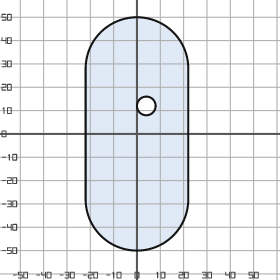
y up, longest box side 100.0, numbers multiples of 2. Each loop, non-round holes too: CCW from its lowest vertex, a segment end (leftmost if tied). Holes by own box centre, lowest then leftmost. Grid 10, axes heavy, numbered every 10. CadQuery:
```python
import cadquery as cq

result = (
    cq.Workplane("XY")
    .moveTo(-22.0, -28.0)
    .threePointArc((0.0, -50.0), (22.0, -28.0))
    .lineTo(22.0, 28.0)
    .threePointArc((0.0, 50.0), (-22.0, 28.0))
    .close()
    .moveTo(4.0, 12.0)
    .circle(4.0)
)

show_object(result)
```